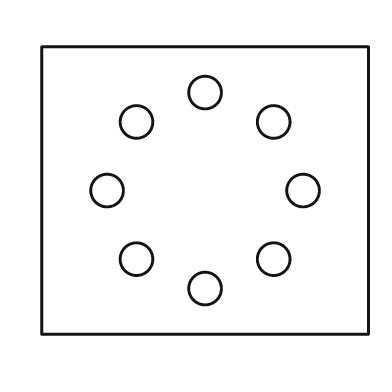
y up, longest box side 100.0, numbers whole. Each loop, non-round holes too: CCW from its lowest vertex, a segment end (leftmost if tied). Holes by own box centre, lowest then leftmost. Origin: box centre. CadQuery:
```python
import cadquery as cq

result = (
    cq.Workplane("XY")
    .moveTo(-50.0, -44.0)
    .lineTo(50.0, -44.0)
    .lineTo(50.0, 44.0)
    .lineTo(-50.0, 44.0)
    .close()
    .moveTo(0.0, -30.0)
    .circle(5.0)
    .moveTo(-21.0, -21.0)
    .circle(5.0)
    .moveTo(21.0, -21.0)
    .circle(5.0)
    .moveTo(-30.0, 0.0)
    .circle(5.0)
    .moveTo(30.0, 0.0)
    .circle(5.0)
    .moveTo(-21.0, 21.0)
    .circle(5.0)
    .moveTo(21.0, 21.0)
    .circle(5.0)
    .moveTo(0.0, 30.0)
    .circle(5.0)
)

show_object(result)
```